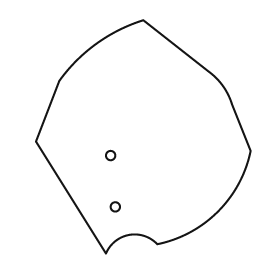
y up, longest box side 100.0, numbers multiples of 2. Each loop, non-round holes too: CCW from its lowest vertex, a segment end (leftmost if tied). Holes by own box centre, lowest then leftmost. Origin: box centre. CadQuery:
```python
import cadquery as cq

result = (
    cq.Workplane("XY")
    .moveTo(-16.0, -50.0)
    .threePointArc((-6.0, -42.0), (6.0, -46.0))
    .threePointArc((32.0, -32.0), (46.0, -6.0))
    .lineTo(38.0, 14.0)
    .threePointArc((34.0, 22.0), (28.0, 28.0))
    .lineTo(0.0, 50.0)
    .threePointArc((-20.0, 40.0), (-36.0, 24.0))
    .lineTo(-46.0, -2.0)
    .close()
    .moveTo(-12.0, -30.0)
    .circle(2.0)
    .moveTo(-14.0, -8.0)
    .circle(2.0)
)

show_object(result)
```